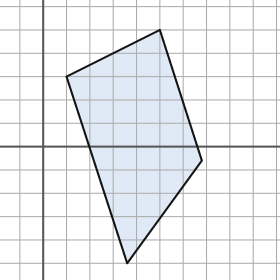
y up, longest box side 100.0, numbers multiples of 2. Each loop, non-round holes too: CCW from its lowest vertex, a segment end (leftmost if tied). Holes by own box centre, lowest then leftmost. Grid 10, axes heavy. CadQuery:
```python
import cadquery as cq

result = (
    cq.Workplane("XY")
    .moveTo(36.0, -50.0)
    .lineTo(68.0, -6.0)
    .lineTo(50.0, 50.0)
    .lineTo(10.0, 30.0)
    .close()
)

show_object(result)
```